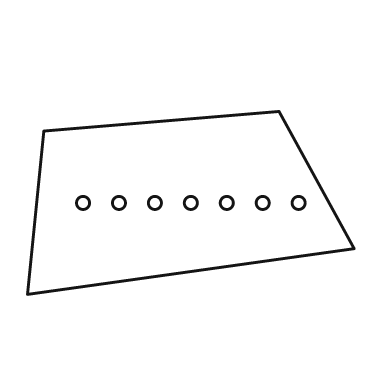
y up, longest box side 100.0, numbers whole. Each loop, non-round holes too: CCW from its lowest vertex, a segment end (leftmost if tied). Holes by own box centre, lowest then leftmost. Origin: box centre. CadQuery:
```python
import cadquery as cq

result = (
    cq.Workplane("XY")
    .moveTo(-50.0, -28.0)
    .lineTo(50.0, -14.0)
    .lineTo(27.0, 28.0)
    .lineTo(-45.0, 22.0)
    .close()
    .moveTo(-33.0, 0.0)
    .circle(2.0)
    .moveTo(-22.0, 0.0)
    .circle(2.0)
    .moveTo(-11.0, 0.0)
    .circle(2.0)
    .moveTo(0.0, 0.0)
    .circle(2.0)
    .moveTo(11.0, 0.0)
    .circle(2.0)
    .moveTo(22.0, 0.0)
    .circle(2.0)
    .moveTo(33.0, 0.0)
    .circle(2.0)
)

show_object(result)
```